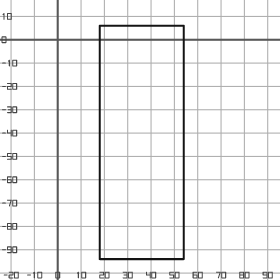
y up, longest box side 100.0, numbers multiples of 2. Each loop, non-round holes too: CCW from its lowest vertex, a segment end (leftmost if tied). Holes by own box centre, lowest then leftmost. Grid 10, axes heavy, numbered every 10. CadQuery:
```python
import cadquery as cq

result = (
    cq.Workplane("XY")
    .moveTo(18.0, -94.0)
    .lineTo(54.0, -94.0)
    .lineTo(54.0, 6.0)
    .lineTo(18.0, 6.0)
    .close()
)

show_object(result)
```